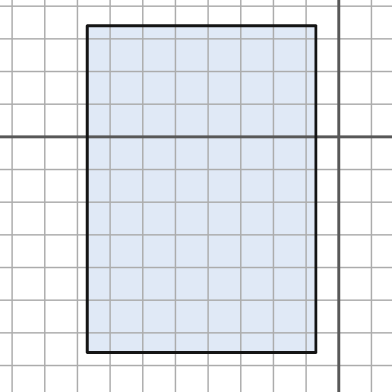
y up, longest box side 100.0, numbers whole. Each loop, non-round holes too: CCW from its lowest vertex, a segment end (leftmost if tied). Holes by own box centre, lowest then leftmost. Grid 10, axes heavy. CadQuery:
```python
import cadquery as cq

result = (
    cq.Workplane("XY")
    .moveTo(-77.0, -66.0)
    .lineTo(-7.0, -66.0)
    .lineTo(-7.0, 34.0)
    .lineTo(-77.0, 34.0)
    .close()
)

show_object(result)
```